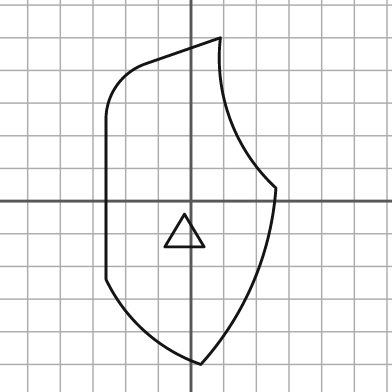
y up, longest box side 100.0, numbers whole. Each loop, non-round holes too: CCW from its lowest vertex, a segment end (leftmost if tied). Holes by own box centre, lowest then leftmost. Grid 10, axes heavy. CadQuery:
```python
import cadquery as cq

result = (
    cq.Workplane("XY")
    .moveTo(3.0, -50.0)
    .threePointArc((19.0, -25.0), (26.0, 4.0))
    .threePointArc((12.0, 25.0), (9.0, 50.0))
    .lineTo(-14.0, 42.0)
    .threePointArc((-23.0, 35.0), (-26.0, 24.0))
    .lineTo(-26.0, -24.0)
    .threePointArc((-14.0, -40.0), (3.0, -50.0))
    .close()
    .moveTo(-8.0, -14.0)
    .lineTo(4.0, -14.0)
    .lineTo(-2.0, -4.0)
    .close()
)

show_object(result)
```